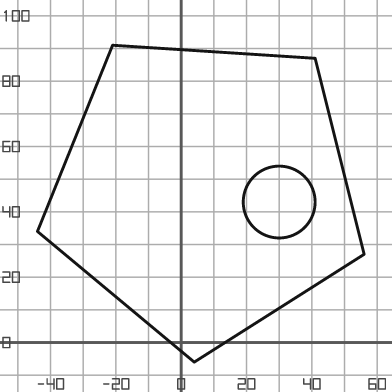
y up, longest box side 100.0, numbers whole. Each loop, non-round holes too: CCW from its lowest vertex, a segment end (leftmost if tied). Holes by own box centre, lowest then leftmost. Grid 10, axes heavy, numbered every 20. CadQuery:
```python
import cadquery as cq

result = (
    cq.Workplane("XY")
    .moveTo(4.0, -6.0)
    .lineTo(56.0, 27.0)
    .lineTo(41.0, 87.0)
    .lineTo(-21.0, 91.0)
    .lineTo(-44.0, 34.0)
    .close()
    .moveTo(30.0, 43.0)
    .circle(11.0)
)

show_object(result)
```